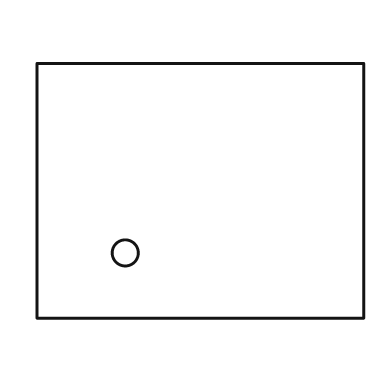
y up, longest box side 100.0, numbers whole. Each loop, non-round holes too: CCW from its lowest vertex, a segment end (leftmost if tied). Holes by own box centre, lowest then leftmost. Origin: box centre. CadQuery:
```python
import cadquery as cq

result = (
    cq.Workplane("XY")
    .moveTo(-50.0, -39.0)
    .lineTo(50.0, -39.0)
    .lineTo(50.0, 39.0)
    .lineTo(-50.0, 39.0)
    .close()
    .moveTo(-23.0, -19.0)
    .circle(4.0)
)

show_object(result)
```